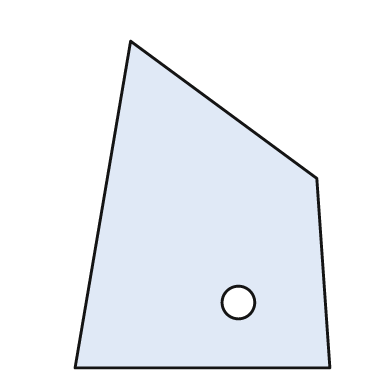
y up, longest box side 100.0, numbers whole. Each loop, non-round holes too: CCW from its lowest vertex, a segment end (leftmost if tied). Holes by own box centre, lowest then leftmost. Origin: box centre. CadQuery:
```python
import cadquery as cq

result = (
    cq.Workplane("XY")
    .moveTo(-39.0, -50.0)
    .lineTo(39.0, -50.0)
    .lineTo(35.0, 8.0)
    .lineTo(-22.0, 50.0)
    .close()
    .moveTo(11.0, -30.0)
    .circle(5.0)
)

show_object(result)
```